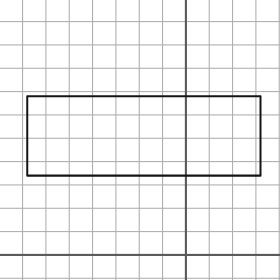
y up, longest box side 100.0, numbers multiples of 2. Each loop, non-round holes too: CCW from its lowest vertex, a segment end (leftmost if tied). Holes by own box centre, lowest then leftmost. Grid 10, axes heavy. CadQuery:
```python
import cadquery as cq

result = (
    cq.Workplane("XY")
    .moveTo(-68.0, 34.0)
    .lineTo(32.0, 34.0)
    .lineTo(32.0, 68.0)
    .lineTo(-68.0, 68.0)
    .close()
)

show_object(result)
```